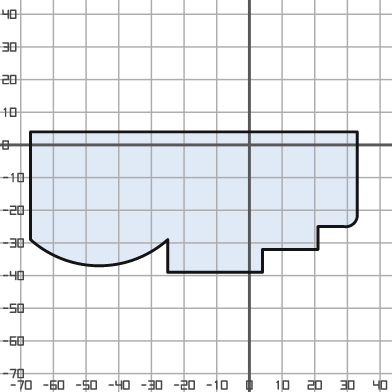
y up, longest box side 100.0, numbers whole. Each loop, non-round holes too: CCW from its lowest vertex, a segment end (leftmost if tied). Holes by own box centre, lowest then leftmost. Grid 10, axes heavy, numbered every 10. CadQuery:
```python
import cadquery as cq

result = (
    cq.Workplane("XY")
    .moveTo(-25.0, -39.0)
    .lineTo(4.0, -39.0)
    .lineTo(4.0, -32.0)
    .lineTo(21.0, -32.0)
    .lineTo(21.0, -25.0)
    .lineTo(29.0, -25.0)
    .threePointArc((32.0, -24.0), (33.0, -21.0))
    .lineTo(33.0, 4.0)
    .lineTo(-67.0, 4.0)
    .lineTo(-67.0, -29.0)
    .threePointArc((-46.0, -37.0), (-25.0, -29.0))
    .close()
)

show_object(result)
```